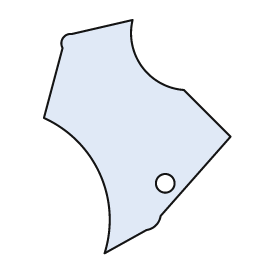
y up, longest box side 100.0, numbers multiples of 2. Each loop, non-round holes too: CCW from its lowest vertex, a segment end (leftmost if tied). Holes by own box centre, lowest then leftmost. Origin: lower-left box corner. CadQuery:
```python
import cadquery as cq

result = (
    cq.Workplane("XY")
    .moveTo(26.0, 0.0)
    .lineTo(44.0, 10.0)
    .threePointArc((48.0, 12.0), (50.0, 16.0))
    .lineTo(80.0, 50.0)
    .lineTo(60.0, 70.0)
    .threePointArc((42.0, 80.0), (38.0, 100.0))
    .lineTo(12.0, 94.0)
    .threePointArc((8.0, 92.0), (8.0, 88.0))
    .lineTo(0.0, 58.0)
    .threePointArc((24.0, 34.0), (26.0, 0.0))
    .close()
    .moveTo(52.0, 30.0)
    .circle(4.0)
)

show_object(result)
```